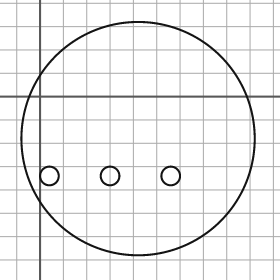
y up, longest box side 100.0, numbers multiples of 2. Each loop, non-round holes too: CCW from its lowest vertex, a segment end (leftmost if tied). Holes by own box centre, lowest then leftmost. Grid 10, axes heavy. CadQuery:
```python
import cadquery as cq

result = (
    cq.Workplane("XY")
    .moveTo(42.0, -18.0)
    .circle(50.0)
    .moveTo(4.0, -34.0)
    .circle(4.0)
    .moveTo(30.0, -34.0)
    .circle(4.0)
    .moveTo(56.0, -34.0)
    .circle(4.0)
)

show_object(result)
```